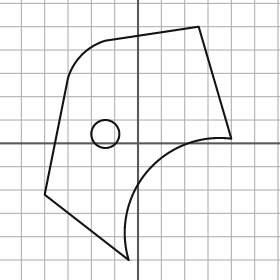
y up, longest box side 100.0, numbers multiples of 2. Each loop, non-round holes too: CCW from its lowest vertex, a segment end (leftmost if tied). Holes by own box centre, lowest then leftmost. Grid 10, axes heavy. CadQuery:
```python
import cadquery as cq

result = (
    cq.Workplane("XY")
    .moveTo(-4.0, -50.0)
    .threePointArc((4.0, -12.0), (40.0, 2.0))
    .lineTo(26.0, 50.0)
    .lineTo(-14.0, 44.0)
    .threePointArc((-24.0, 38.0), (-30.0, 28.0))
    .lineTo(-40.0, -22.0)
    .close()
    .moveTo(-14.0, 4.0)
    .circle(6.0)
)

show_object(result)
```